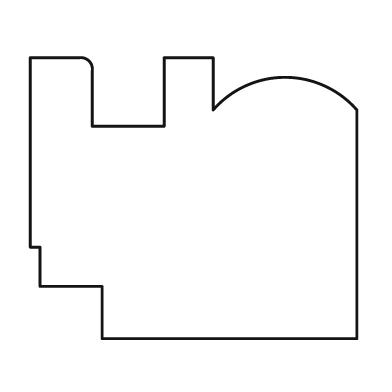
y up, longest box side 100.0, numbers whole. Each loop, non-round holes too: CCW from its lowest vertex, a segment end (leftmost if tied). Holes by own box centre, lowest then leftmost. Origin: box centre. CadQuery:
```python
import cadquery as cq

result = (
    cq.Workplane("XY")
    .moveTo(-28.0, -43.0)
    .lineTo(50.0, -43.0)
    .lineTo(50.0, 27.0)
    .threePointArc((28.0, 37.0), (6.0, 27.0))
    .lineTo(6.0, 43.0)
    .lineTo(-9.0, 43.0)
    .lineTo(-9.0, 22.0)
    .lineTo(-31.0, 22.0)
    .lineTo(-31.0, 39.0)
    .threePointArc((-32.0, 42.0), (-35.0, 43.0))
    .lineTo(-50.0, 43.0)
    .lineTo(-50.0, -15.0)
    .lineTo(-47.0, -15.0)
    .lineTo(-47.0, -27.0)
    .lineTo(-28.0, -27.0)
    .close()
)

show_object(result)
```